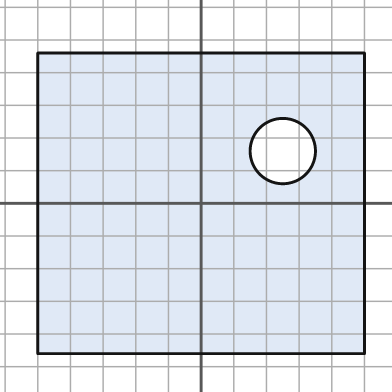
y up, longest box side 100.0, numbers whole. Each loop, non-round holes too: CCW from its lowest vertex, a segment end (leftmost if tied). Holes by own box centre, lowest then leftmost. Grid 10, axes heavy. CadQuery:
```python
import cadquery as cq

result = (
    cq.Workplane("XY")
    .moveTo(-50.0, -46.0)
    .lineTo(50.0, -46.0)
    .lineTo(50.0, 46.0)
    .lineTo(-50.0, 46.0)
    .close()
    .moveTo(25.0, 16.0)
    .circle(10.0)
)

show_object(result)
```